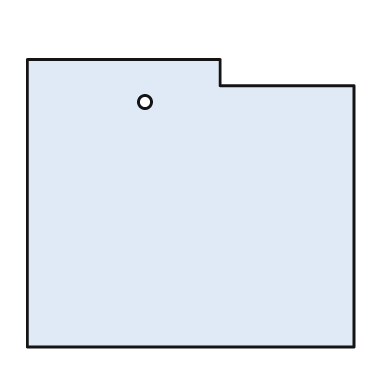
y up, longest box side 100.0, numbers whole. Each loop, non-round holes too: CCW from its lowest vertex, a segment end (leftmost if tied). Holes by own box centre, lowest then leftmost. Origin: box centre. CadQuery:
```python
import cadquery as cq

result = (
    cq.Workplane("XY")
    .moveTo(-50.0, -44.0)
    .lineTo(50.0, -44.0)
    .lineTo(50.0, 36.0)
    .lineTo(9.0, 36.0)
    .lineTo(9.0, 44.0)
    .lineTo(-50.0, 44.0)
    .close()
    .moveTo(-14.0, 31.0)
    .circle(2.0)
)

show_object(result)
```